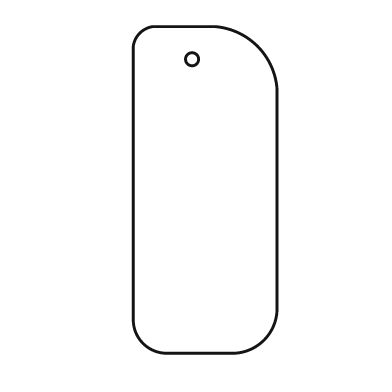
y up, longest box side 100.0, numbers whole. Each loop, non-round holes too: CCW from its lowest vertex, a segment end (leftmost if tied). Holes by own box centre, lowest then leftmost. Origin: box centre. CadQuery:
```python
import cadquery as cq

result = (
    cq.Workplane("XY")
    .moveTo(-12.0, -50.0)
    .lineTo(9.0, -50.0)
    .threePointArc((18.0, -46.0), (22.0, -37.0))
    .lineTo(22.0, 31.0)
    .threePointArc((16.0, 44.0), (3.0, 50.0))
    .lineTo(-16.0, 50.0)
    .threePointArc((-20.0, 48.0), (-22.0, 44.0))
    .lineTo(-22.0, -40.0)
    .threePointArc((-19.0, -47.0), (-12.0, -50.0))
    .close()
    .moveTo(-4.0, 40.0)
    .circle(2.0)
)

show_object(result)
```